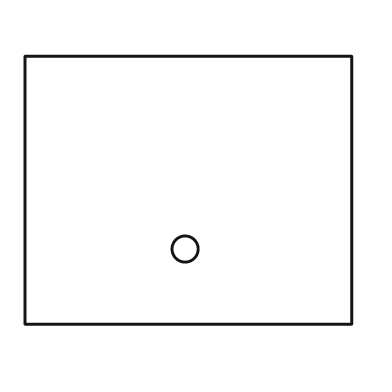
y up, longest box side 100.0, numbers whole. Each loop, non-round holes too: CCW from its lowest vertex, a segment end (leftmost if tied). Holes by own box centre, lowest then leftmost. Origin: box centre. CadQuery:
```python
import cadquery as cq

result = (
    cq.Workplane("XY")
    .moveTo(-50.0, -41.0)
    .lineTo(50.0, -41.0)
    .lineTo(50.0, 41.0)
    .lineTo(-50.0, 41.0)
    .close()
    .moveTo(-1.0, -18.0)
    .circle(4.0)
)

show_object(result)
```